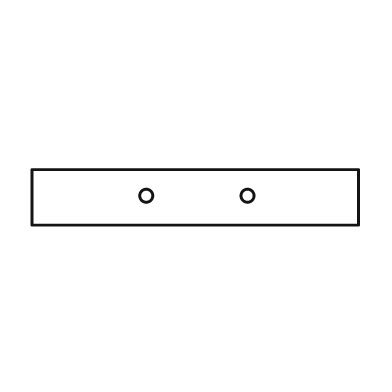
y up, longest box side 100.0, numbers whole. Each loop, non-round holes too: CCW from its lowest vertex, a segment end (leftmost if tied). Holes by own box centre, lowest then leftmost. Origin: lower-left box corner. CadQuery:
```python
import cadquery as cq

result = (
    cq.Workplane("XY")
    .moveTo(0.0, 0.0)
    .lineTo(100.0, 0.0)
    .lineTo(100.0, 17.0)
    .lineTo(0.0, 17.0)
    .close()
    .moveTo(35.0, 9.0)
    .circle(2.0)
    .moveTo(66.0, 9.0)
    .circle(2.0)
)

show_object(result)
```